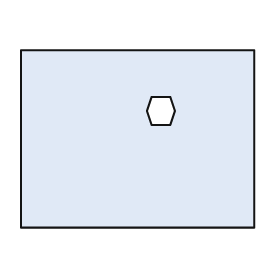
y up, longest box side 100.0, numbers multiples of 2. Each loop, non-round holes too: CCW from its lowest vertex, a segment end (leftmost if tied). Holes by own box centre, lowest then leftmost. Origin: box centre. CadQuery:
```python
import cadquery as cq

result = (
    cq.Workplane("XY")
    .moveTo(-50.0, -38.0)
    .lineTo(50.0, -38.0)
    .lineTo(50.0, 38.0)
    .lineTo(-50.0, 38.0)
    .close()
    .moveTo(6.0, 6.0)
    .lineTo(14.0, 6.0)
    .lineTo(16.0, 12.0)
    .lineTo(14.0, 18.0)
    .lineTo(6.0, 18.0)
    .lineTo(4.0, 12.0)
    .close()
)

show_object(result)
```